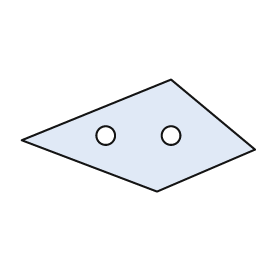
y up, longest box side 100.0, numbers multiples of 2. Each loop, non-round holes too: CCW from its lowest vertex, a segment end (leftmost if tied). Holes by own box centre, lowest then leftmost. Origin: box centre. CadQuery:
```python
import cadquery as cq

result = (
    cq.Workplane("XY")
    .moveTo(8.0, -24.0)
    .lineTo(50.0, -6.0)
    .lineTo(14.0, 24.0)
    .lineTo(-50.0, -2.0)
    .close()
    .moveTo(-14.0, 0.0)
    .circle(4.0)
    .moveTo(14.0, 0.0)
    .circle(4.0)
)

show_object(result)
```